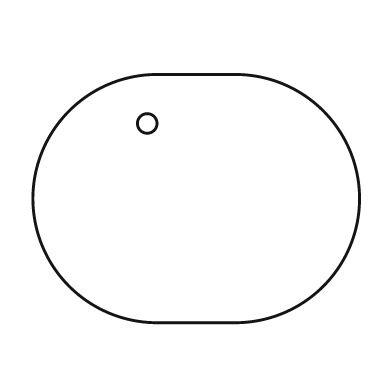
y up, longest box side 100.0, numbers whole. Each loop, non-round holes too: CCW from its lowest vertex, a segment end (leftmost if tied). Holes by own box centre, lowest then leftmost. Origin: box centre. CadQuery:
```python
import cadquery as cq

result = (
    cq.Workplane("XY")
    .moveTo(-12.0, -38.0)
    .lineTo(12.0, -38.0)
    .threePointArc((50.0, 0.0), (12.0, 38.0))
    .lineTo(-12.0, 38.0)
    .threePointArc((-50.0, 0.0), (-12.0, -38.0))
    .close()
    .moveTo(-15.0, 23.0)
    .circle(3.0)
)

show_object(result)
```